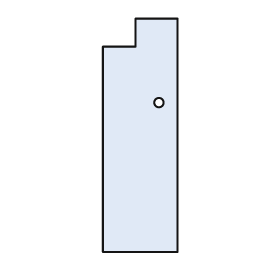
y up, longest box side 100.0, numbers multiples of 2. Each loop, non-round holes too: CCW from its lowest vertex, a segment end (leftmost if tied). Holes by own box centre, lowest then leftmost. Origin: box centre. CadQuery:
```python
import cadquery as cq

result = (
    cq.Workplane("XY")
    .moveTo(-16.0, -50.0)
    .lineTo(16.0, -50.0)
    .lineTo(16.0, 50.0)
    .lineTo(-2.0, 50.0)
    .lineTo(-2.0, 38.0)
    .lineTo(-16.0, 38.0)
    .close()
    .moveTo(8.0, 14.0)
    .circle(2.0)
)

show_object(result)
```